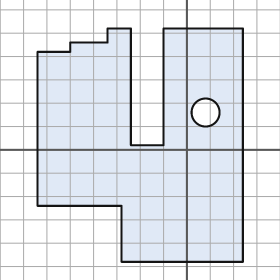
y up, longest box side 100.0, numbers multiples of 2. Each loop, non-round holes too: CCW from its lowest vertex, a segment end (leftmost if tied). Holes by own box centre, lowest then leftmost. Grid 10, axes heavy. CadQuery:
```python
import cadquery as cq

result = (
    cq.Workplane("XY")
    .moveTo(-28.0, -48.0)
    .lineTo(24.0, -48.0)
    .lineTo(24.0, 52.0)
    .lineTo(-10.0, 52.0)
    .lineTo(-10.0, 2.0)
    .lineTo(-24.0, 2.0)
    .lineTo(-24.0, 52.0)
    .lineTo(-34.0, 52.0)
    .lineTo(-34.0, 46.0)
    .lineTo(-50.0, 46.0)
    .lineTo(-50.0, 42.0)
    .lineTo(-64.0, 42.0)
    .lineTo(-64.0, -24.0)
    .lineTo(-28.0, -24.0)
    .close()
    .moveTo(8.0, 16.0)
    .circle(6.0)
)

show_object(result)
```